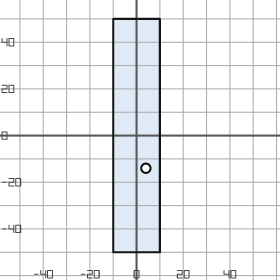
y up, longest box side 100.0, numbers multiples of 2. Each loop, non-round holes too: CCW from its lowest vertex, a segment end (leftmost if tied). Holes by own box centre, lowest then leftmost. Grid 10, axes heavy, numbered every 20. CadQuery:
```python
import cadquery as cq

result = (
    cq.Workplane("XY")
    .moveTo(-10.0, -50.0)
    .lineTo(10.0, -50.0)
    .lineTo(10.0, 50.0)
    .lineTo(-10.0, 50.0)
    .close()
    .moveTo(4.0, -14.0)
    .circle(2.0)
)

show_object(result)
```